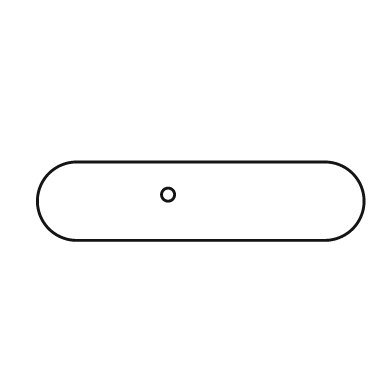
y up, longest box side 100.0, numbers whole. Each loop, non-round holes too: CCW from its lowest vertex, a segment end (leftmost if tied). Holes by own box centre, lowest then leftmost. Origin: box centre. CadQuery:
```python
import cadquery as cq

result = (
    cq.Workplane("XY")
    .moveTo(-38.0, -12.0)
    .lineTo(38.0, -12.0)
    .threePointArc((50.0, 0.0), (38.0, 12.0))
    .lineTo(-38.0, 12.0)
    .threePointArc((-50.0, 0.0), (-38.0, -12.0))
    .close()
    .moveTo(-10.0, 2.0)
    .circle(2.0)
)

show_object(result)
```